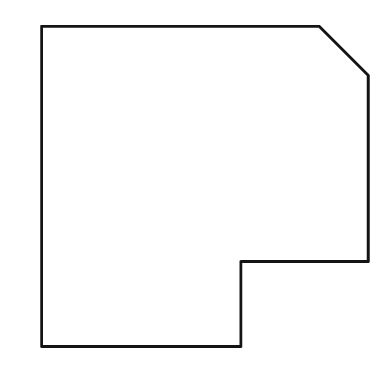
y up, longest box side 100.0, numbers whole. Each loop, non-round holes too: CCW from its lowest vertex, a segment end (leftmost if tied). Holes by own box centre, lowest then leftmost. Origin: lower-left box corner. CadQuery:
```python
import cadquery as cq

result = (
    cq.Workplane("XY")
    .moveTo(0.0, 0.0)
    .lineTo(61.0, 0.0)
    .lineTo(61.0, 26.0)
    .lineTo(100.0, 26.0)
    .lineTo(100.0, 83.0)
    .lineTo(85.0, 98.0)
    .lineTo(0.0, 98.0)
    .close()
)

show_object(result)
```